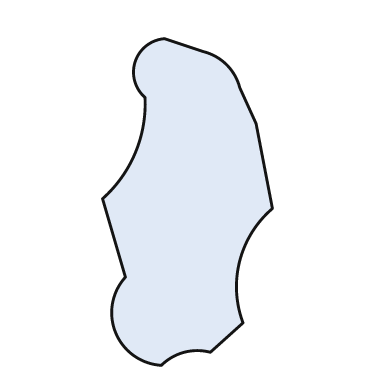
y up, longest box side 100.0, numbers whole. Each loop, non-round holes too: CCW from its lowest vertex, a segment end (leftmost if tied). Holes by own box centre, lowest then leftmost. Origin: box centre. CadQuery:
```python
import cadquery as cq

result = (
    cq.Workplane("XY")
    .moveTo(-8.0, -50.0)
    .threePointArc((-1.0, -46.0), (7.0, -46.0))
    .lineTo(17.0, -37.0)
    .threePointArc((16.0, -18.0), (26.0, -2.0))
    .lineTo(21.0, 24.0)
    .lineTo(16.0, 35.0)
    .threePointArc((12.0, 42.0), (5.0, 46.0))
    .lineTo(-7.0, 50.0)
    .threePointArc((-16.0, 43.0), (-13.0, 32.0))
    .threePointArc((-16.0, 15.0), (-26.0, 1.0))
    .lineTo(-19.0, -23.0)
    .threePointArc((-22.0, -40.0), (-8.0, -50.0))
    .close()
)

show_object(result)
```